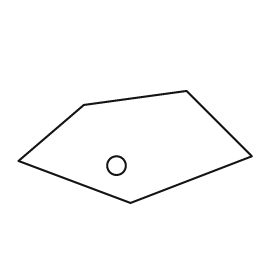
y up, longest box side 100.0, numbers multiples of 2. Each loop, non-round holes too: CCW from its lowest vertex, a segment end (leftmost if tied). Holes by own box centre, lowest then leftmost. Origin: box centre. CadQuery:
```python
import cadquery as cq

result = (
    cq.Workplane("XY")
    .moveTo(-2.0, -24.0)
    .lineTo(50.0, -4.0)
    .lineTo(22.0, 24.0)
    .lineTo(-22.0, 18.0)
    .lineTo(-50.0, -6.0)
    .close()
    .moveTo(-8.0, -8.0)
    .circle(4.0)
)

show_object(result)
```